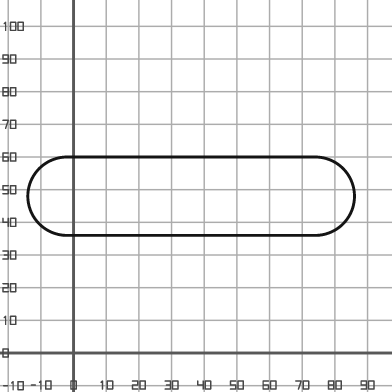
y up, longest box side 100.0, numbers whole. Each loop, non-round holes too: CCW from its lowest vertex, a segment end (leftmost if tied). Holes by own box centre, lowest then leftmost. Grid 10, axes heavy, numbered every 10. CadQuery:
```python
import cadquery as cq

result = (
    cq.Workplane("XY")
    .moveTo(-2.0, 36.0)
    .lineTo(74.0, 36.0)
    .threePointArc((86.0, 48.0), (74.0, 60.0))
    .lineTo(-2.0, 60.0)
    .threePointArc((-14.0, 48.0), (-2.0, 36.0))
    .close()
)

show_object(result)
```